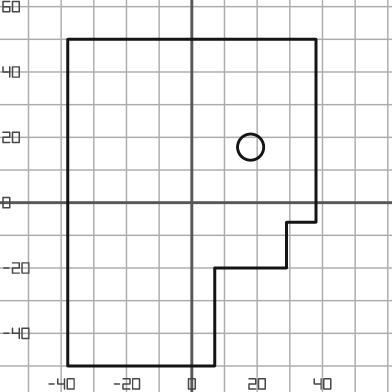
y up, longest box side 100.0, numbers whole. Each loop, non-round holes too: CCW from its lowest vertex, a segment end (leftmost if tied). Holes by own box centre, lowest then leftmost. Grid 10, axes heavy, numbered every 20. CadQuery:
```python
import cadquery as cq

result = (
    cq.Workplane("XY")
    .moveTo(-38.0, -50.0)
    .lineTo(7.0, -50.0)
    .lineTo(7.0, -20.0)
    .lineTo(29.0, -20.0)
    .lineTo(29.0, -6.0)
    .lineTo(38.0, -6.0)
    .lineTo(38.0, 50.0)
    .lineTo(-38.0, 50.0)
    .close()
    .moveTo(18.0, 17.0)
    .circle(4.0)
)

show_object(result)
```